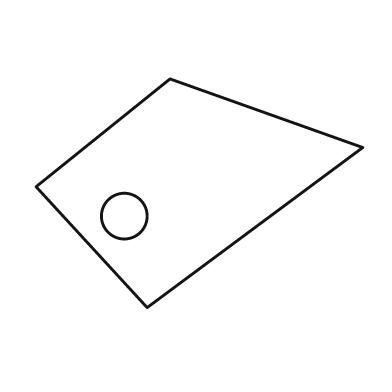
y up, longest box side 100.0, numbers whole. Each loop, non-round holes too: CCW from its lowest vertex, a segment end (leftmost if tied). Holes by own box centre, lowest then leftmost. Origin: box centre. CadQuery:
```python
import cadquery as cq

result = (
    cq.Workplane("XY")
    .moveTo(-16.0, -35.0)
    .lineTo(50.0, 14.0)
    .lineTo(-9.0, 35.0)
    .lineTo(-50.0, 2.0)
    .close()
    .moveTo(-23.0, -7.0)
    .circle(7.0)
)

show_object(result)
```